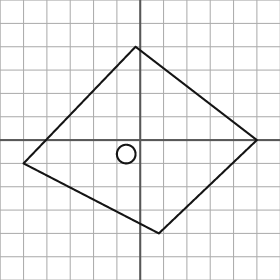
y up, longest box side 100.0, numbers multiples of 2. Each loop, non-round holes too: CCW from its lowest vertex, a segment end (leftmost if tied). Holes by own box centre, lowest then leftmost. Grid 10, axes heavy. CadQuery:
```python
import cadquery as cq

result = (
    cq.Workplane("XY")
    .moveTo(8.0, -40.0)
    .lineTo(50.0, 0.0)
    .lineTo(-2.0, 40.0)
    .lineTo(-50.0, -10.0)
    .close()
    .moveTo(-6.0, -6.0)
    .circle(4.0)
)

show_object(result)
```